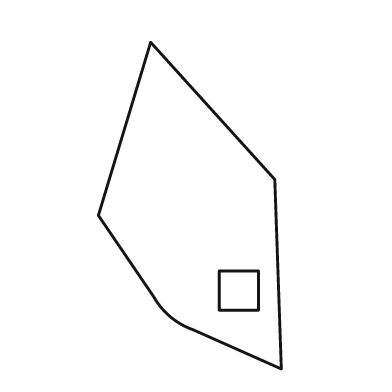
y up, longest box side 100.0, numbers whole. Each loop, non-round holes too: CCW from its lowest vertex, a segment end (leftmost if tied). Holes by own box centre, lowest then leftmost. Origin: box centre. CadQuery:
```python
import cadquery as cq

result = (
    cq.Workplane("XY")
    .moveTo(28.0, -50.0)
    .lineTo(26.0, 8.0)
    .lineTo(-12.0, 50.0)
    .lineTo(-28.0, -3.0)
    .lineTo(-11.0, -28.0)
    .threePointArc((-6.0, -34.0), (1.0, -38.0))
    .close()
    .moveTo(9.0, -32.0)
    .lineTo(21.0, -32.0)
    .lineTo(21.0, -20.0)
    .lineTo(9.0, -20.0)
    .close()
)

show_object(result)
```